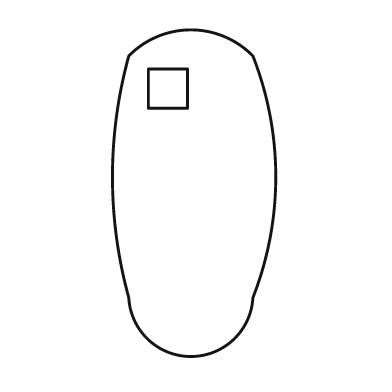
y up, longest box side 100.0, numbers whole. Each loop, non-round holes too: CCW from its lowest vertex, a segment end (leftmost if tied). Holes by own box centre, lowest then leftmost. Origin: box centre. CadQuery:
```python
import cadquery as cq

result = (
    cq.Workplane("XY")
    .moveTo(-20.0, -32.0)
    .threePointArc((-1.0, -50.0), (18.0, -32.0))
    .threePointArc((25.0, 5.0), (18.0, 42.0))
    .threePointArc((-1.0, 50.0), (-20.0, 42.0))
    .threePointArc((-25.0, 5.0), (-20.0, -32.0))
    .close()
    .moveTo(-14.0, 26.0)
    .lineTo(-2.0, 26.0)
    .lineTo(-2.0, 38.0)
    .lineTo(-14.0, 38.0)
    .close()
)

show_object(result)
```